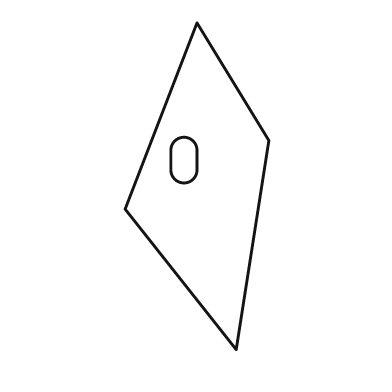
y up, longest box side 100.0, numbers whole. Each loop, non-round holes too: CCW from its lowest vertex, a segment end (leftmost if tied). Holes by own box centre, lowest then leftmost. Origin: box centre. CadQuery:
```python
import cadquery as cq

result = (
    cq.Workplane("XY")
    .moveTo(12.0, -50.0)
    .lineTo(22.0, 14.0)
    .lineTo(0.0, 50.0)
    .lineTo(-22.0, -7.0)
    .close()
    .moveTo(-8.0, 5.0)
    .threePointArc((-4.0, 1.0), (0.0, 5.0))
    .lineTo(0.0, 11.0)
    .threePointArc((-4.0, 15.0), (-8.0, 11.0))
    .close()
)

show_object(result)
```